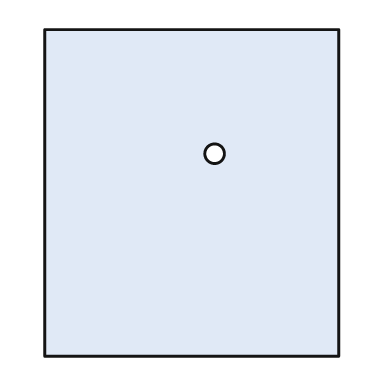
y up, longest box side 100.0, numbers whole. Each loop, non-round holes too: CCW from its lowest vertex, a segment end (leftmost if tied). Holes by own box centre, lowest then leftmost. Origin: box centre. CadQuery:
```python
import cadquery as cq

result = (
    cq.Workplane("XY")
    .moveTo(-45.0, -50.0)
    .lineTo(45.0, -50.0)
    .lineTo(45.0, 50.0)
    .lineTo(-45.0, 50.0)
    .close()
    .moveTo(7.0, 12.0)
    .circle(3.0)
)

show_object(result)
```